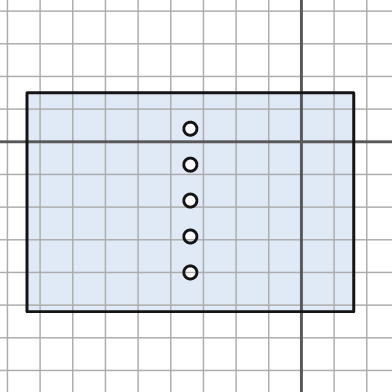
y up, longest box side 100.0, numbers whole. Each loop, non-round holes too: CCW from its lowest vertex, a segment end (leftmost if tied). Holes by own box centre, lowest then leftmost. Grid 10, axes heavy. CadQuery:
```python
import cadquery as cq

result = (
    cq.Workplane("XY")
    .moveTo(-84.0, -52.0)
    .lineTo(16.0, -52.0)
    .lineTo(16.0, 15.0)
    .lineTo(-84.0, 15.0)
    .close()
    .moveTo(-34.0, -40.0)
    .circle(2.0)
    .moveTo(-34.0, -29.0)
    .circle(2.0)
    .moveTo(-34.0, -18.0)
    .circle(2.0)
    .moveTo(-34.0, -7.0)
    .circle(2.0)
    .moveTo(-34.0, 4.0)
    .circle(2.0)
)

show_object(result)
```